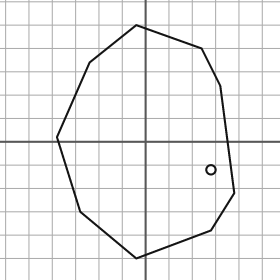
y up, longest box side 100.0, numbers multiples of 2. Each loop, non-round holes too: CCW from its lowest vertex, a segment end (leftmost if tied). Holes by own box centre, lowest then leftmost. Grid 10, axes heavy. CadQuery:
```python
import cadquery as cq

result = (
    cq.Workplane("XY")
    .moveTo(-4.0, -50.0)
    .lineTo(28.0, -38.0)
    .lineTo(38.0, -22.0)
    .lineTo(32.0, 24.0)
    .lineTo(24.0, 40.0)
    .lineTo(-4.0, 50.0)
    .lineTo(-24.0, 34.0)
    .lineTo(-38.0, 2.0)
    .lineTo(-28.0, -30.0)
    .close()
    .moveTo(28.0, -12.0)
    .circle(2.0)
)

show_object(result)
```